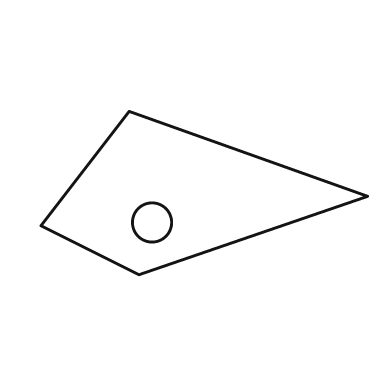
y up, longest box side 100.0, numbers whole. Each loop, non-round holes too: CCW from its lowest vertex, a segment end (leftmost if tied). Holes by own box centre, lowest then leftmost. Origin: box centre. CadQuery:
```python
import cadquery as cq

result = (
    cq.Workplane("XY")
    .moveTo(-20.0, -25.0)
    .lineTo(50.0, -1.0)
    .lineTo(-23.0, 25.0)
    .lineTo(-50.0, -10.0)
    .close()
    .moveTo(-16.0, -9.0)
    .circle(6.0)
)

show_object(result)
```